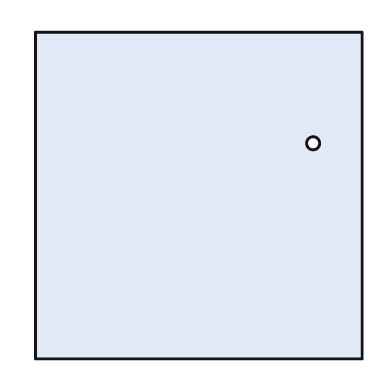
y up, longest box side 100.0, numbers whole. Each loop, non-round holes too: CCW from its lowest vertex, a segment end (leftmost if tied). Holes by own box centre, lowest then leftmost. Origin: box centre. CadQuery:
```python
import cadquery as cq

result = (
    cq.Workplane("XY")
    .moveTo(-50.0, -50.0)
    .lineTo(50.0, -50.0)
    .lineTo(50.0, 50.0)
    .lineTo(-50.0, 50.0)
    .close()
    .moveTo(35.0, 16.0)
    .circle(2.0)
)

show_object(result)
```